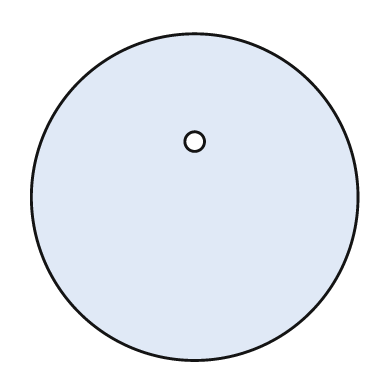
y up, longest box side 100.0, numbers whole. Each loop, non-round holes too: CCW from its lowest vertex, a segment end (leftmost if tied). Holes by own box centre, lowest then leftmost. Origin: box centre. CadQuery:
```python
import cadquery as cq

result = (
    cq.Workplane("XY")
    .moveTo(0.0, 0.0)
    .circle(50.0)
    .moveTo(0.0, 17.0)
    .circle(3.0)
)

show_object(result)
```